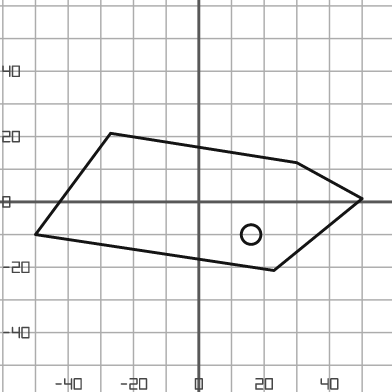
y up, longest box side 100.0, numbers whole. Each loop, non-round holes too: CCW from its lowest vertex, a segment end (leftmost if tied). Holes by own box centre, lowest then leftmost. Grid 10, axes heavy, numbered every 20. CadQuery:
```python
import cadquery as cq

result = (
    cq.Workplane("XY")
    .moveTo(23.0, -21.0)
    .lineTo(50.0, 1.0)
    .lineTo(30.0, 12.0)
    .lineTo(-27.0, 21.0)
    .lineTo(-50.0, -10.0)
    .close()
    .moveTo(16.0, -10.0)
    .circle(3.0)
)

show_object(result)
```